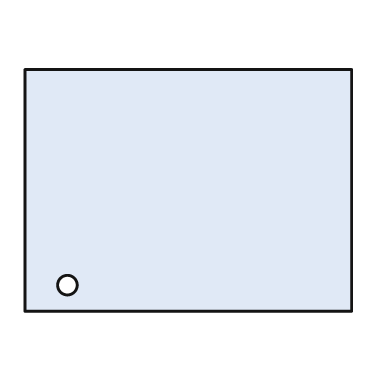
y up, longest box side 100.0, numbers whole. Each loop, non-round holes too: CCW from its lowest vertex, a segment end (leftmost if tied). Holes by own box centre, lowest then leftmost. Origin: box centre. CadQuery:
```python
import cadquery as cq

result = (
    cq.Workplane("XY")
    .moveTo(-50.0, -37.0)
    .lineTo(50.0, -37.0)
    .lineTo(50.0, 37.0)
    .lineTo(-50.0, 37.0)
    .close()
    .moveTo(-37.0, -29.0)
    .circle(3.0)
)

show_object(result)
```